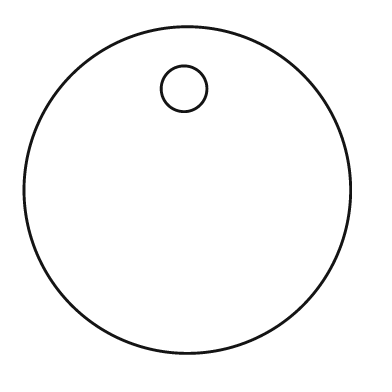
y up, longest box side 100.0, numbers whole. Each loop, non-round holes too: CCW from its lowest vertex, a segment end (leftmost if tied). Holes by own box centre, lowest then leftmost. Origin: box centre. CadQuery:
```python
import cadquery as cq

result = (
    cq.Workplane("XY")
    .moveTo(0.0, 0.0)
    .circle(50.0)
    .moveTo(-1.0, 31.0)
    .circle(7.0)
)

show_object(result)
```